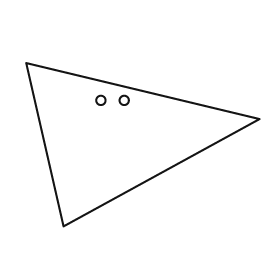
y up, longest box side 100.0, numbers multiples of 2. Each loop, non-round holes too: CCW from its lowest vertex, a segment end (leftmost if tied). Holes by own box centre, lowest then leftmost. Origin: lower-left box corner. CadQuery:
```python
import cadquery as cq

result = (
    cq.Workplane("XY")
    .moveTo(16.0, 0.0)
    .lineTo(100.0, 46.0)
    .lineTo(0.0, 70.0)
    .close()
    .moveTo(32.0, 54.0)
    .circle(2.0)
    .moveTo(42.0, 54.0)
    .circle(2.0)
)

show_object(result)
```